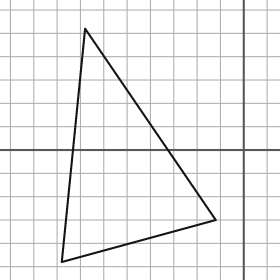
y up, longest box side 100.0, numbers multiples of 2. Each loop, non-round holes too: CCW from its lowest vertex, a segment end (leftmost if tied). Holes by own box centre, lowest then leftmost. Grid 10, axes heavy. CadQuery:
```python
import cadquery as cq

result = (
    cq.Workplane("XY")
    .moveTo(-78.0, -48.0)
    .lineTo(-12.0, -30.0)
    .lineTo(-68.0, 52.0)
    .close()
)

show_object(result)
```